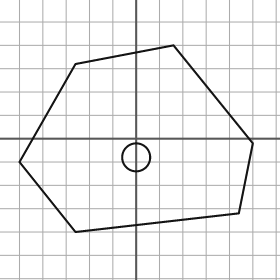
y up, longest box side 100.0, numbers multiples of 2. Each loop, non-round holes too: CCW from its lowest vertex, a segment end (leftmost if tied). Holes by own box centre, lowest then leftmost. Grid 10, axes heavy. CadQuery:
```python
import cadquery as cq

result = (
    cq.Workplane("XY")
    .moveTo(-26.0, -40.0)
    .lineTo(44.0, -32.0)
    .lineTo(50.0, -2.0)
    .lineTo(16.0, 40.0)
    .lineTo(-26.0, 32.0)
    .lineTo(-50.0, -10.0)
    .close()
    .moveTo(0.0, -8.0)
    .circle(6.0)
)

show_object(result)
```